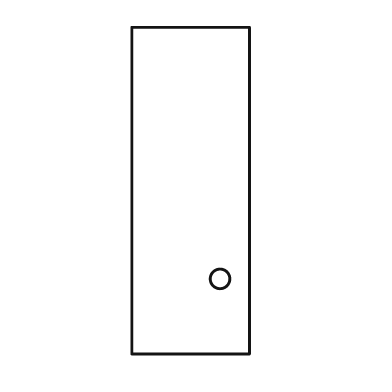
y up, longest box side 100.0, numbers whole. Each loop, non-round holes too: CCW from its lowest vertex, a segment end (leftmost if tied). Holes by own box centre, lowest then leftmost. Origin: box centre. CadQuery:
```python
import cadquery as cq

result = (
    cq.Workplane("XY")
    .moveTo(-18.0, -50.0)
    .lineTo(18.0, -50.0)
    .lineTo(18.0, 50.0)
    .lineTo(-18.0, 50.0)
    .close()
    .moveTo(9.0, -27.0)
    .circle(3.0)
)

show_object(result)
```